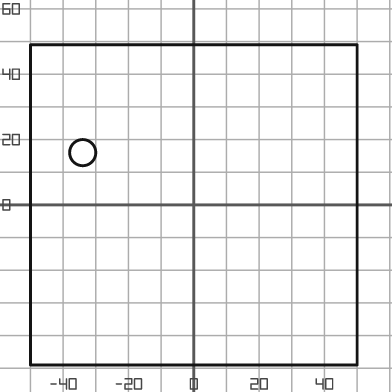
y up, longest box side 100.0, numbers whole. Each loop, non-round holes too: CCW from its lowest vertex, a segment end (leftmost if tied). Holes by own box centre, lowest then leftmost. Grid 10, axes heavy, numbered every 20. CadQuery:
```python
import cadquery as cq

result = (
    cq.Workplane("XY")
    .moveTo(-50.0, -49.0)
    .lineTo(50.0, -49.0)
    .lineTo(50.0, 49.0)
    .lineTo(-50.0, 49.0)
    .close()
    .moveTo(-34.0, 16.0)
    .circle(4.0)
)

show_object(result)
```